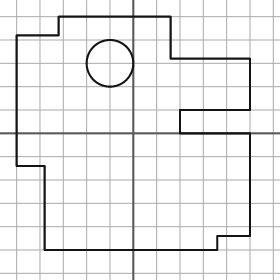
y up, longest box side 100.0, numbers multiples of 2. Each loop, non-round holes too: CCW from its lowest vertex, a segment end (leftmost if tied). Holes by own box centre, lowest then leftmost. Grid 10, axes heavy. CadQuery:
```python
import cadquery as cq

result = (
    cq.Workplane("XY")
    .moveTo(-38.0, -50.0)
    .lineTo(36.0, -50.0)
    .lineTo(36.0, -44.0)
    .lineTo(50.0, -44.0)
    .lineTo(50.0, 0.0)
    .lineTo(20.0, 0.0)
    .lineTo(20.0, 10.0)
    .lineTo(50.0, 10.0)
    .lineTo(50.0, 32.0)
    .lineTo(16.0, 32.0)
    .lineTo(16.0, 50.0)
    .lineTo(-32.0, 50.0)
    .lineTo(-32.0, 42.0)
    .lineTo(-50.0, 42.0)
    .lineTo(-50.0, -14.0)
    .lineTo(-38.0, -14.0)
    .close()
    .moveTo(-10.0, 30.0)
    .circle(10.0)
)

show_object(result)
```